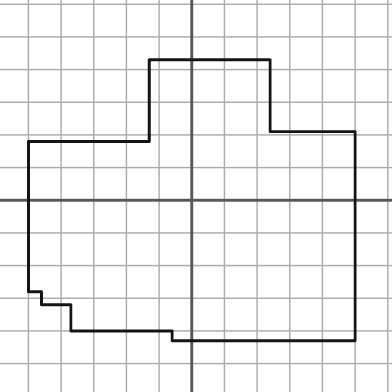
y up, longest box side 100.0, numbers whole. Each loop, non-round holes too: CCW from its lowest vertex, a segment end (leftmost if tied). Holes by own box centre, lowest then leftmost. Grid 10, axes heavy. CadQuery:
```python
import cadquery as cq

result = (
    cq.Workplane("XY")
    .moveTo(-6.0, -43.0)
    .lineTo(50.0, -43.0)
    .lineTo(50.0, 21.0)
    .lineTo(24.0, 21.0)
    .lineTo(24.0, 43.0)
    .lineTo(-13.0, 43.0)
    .lineTo(-13.0, 18.0)
    .lineTo(-50.0, 18.0)
    .lineTo(-50.0, -28.0)
    .lineTo(-46.0, -28.0)
    .lineTo(-46.0, -32.0)
    .lineTo(-37.0, -32.0)
    .lineTo(-37.0, -40.0)
    .lineTo(-6.0, -40.0)
    .close()
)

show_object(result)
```